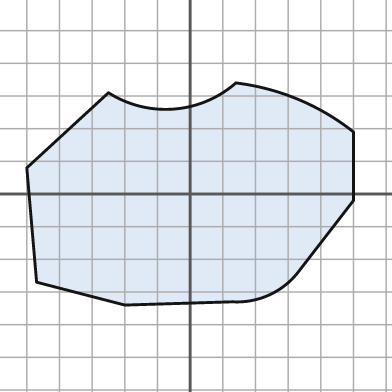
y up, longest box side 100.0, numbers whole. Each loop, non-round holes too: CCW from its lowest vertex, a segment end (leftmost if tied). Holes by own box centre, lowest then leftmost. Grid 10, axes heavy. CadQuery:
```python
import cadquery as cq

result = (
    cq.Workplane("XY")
    .moveTo(-20.0, -34.0)
    .lineTo(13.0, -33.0)
    .threePointArc((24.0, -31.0), (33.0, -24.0))
    .lineTo(50.0, -2.0)
    .lineTo(50.0, 19.0)
    .threePointArc((33.0, 29.0), (14.0, 34.0))
    .threePointArc((-5.0, 26.0), (-25.0, 31.0))
    .lineTo(-50.0, 8.0)
    .lineTo(-47.0, -27.0)
    .close()
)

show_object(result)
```